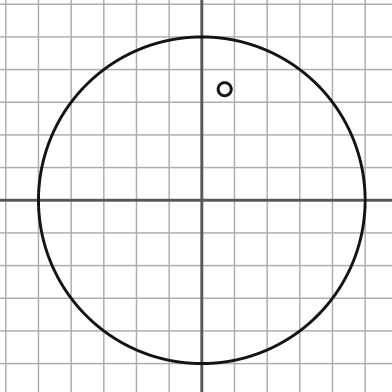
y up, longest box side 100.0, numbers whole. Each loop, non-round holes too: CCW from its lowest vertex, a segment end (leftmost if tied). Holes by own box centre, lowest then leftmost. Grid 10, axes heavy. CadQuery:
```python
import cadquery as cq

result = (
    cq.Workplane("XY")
    .moveTo(0.0, 0.0)
    .circle(50.0)
    .moveTo(7.0, 34.0)
    .circle(2.0)
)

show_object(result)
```